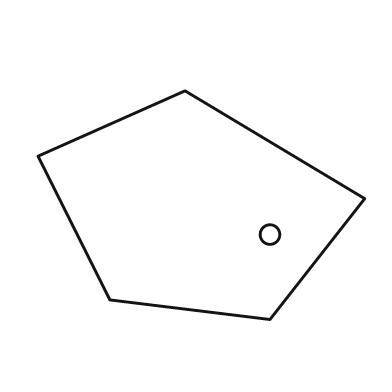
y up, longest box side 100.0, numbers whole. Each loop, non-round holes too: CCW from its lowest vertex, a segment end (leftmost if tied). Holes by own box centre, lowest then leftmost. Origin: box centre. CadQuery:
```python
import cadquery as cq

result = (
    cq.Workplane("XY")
    .moveTo(21.0, -35.0)
    .lineTo(50.0, 2.0)
    .lineTo(-5.0, 35.0)
    .lineTo(-50.0, 15.0)
    .lineTo(-28.0, -29.0)
    .close()
    .moveTo(21.0, -9.0)
    .circle(3.0)
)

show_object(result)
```